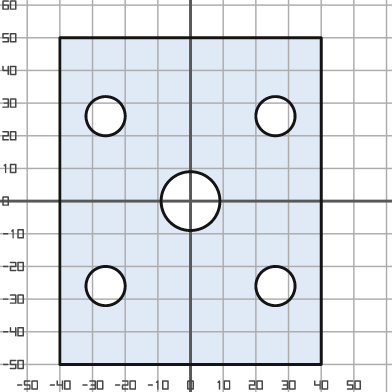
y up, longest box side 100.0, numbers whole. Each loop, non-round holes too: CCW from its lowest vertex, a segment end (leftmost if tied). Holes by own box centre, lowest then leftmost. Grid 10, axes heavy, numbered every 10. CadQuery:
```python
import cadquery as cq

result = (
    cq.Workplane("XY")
    .moveTo(-40.0, -50.0)
    .lineTo(40.0, -50.0)
    .lineTo(40.0, 50.0)
    .lineTo(-40.0, 50.0)
    .close()
    .moveTo(-26.0, -26.0)
    .circle(6.0)
    .moveTo(26.0, -26.0)
    .circle(6.0)
    .moveTo(0.0, 0.0)
    .circle(9.0)
    .moveTo(-26.0, 26.0)
    .circle(6.0)
    .moveTo(26.0, 26.0)
    .circle(6.0)
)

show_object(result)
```